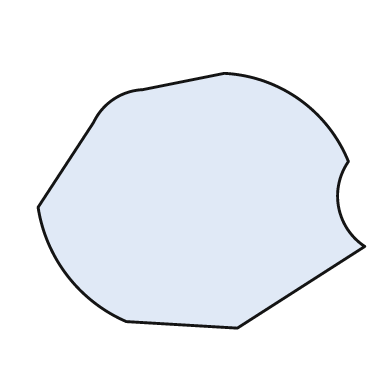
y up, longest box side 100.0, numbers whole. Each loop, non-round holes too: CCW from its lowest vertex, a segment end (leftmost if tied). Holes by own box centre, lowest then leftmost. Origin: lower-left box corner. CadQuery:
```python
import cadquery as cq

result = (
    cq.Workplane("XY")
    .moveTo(61.0, 0.0)
    .lineTo(100.0, 25.0)
    .threePointArc((92.0, 37.0), (95.0, 51.0))
    .threePointArc((80.0, 70.0), (57.0, 78.0))
    .lineTo(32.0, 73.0)
    .threePointArc((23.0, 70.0), (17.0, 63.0))
    .lineTo(0.0, 37.0)
    .threePointArc((9.0, 16.0), (27.0, 2.0))
    .close()
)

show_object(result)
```